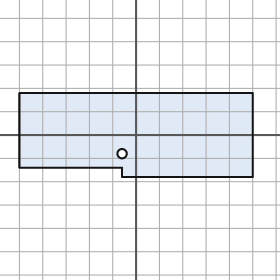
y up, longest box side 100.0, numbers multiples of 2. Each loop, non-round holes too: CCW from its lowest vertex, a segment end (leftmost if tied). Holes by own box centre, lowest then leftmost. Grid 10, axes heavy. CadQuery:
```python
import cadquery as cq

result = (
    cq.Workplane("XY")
    .moveTo(-6.0, -18.0)
    .lineTo(50.0, -18.0)
    .lineTo(50.0, 18.0)
    .lineTo(-50.0, 18.0)
    .lineTo(-50.0, -14.0)
    .lineTo(-6.0, -14.0)
    .close()
    .moveTo(-6.0, -8.0)
    .circle(2.0)
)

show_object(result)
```